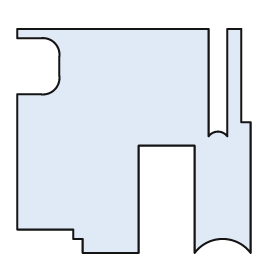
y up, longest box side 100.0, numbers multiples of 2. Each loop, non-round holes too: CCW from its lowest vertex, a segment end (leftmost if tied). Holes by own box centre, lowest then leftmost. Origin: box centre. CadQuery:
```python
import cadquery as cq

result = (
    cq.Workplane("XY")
    .moveTo(-22.0, -48.0)
    .lineTo(2.0, -48.0)
    .lineTo(2.0, -2.0)
    .lineTo(26.0, -2.0)
    .lineTo(26.0, -48.0)
    .threePointArc((38.0, -42.0), (50.0, -48.0))
    .lineTo(50.0, 8.0)
    .lineTo(46.0, 8.0)
    .lineTo(46.0, 48.0)
    .lineTo(40.0, 48.0)
    .lineTo(40.0, 2.0)
    .threePointArc((36.0, 4.0), (32.0, 2.0))
    .lineTo(32.0, 48.0)
    .lineTo(-50.0, 48.0)
    .lineTo(-50.0, 44.0)
    .lineTo(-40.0, 44.0)
    .threePointArc((-34.0, 42.0), (-32.0, 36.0))
    .lineTo(-32.0, 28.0)
    .threePointArc((-34.0, 22.0), (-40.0, 20.0))
    .lineTo(-50.0, 20.0)
    .lineTo(-50.0, -38.0)
    .lineTo(-26.0, -38.0)
    .lineTo(-26.0, -42.0)
    .lineTo(-22.0, -42.0)
    .close()
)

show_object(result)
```